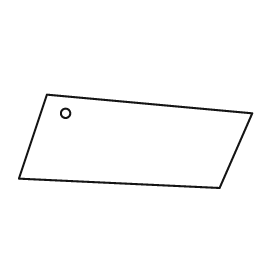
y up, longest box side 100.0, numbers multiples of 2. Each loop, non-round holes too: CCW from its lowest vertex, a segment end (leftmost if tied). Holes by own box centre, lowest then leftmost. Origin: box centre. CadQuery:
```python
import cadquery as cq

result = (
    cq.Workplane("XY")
    .moveTo(36.0, -20.0)
    .lineTo(50.0, 12.0)
    .lineTo(-38.0, 20.0)
    .lineTo(-50.0, -16.0)
    .close()
    .moveTo(-30.0, 12.0)
    .circle(2.0)
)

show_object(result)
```